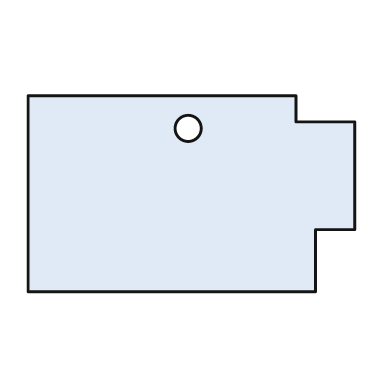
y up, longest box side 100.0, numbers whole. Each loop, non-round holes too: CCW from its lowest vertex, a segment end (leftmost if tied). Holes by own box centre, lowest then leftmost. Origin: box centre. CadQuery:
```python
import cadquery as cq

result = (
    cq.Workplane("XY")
    .moveTo(-50.0, -30.0)
    .lineTo(38.0, -30.0)
    .lineTo(38.0, -11.0)
    .lineTo(50.0, -11.0)
    .lineTo(50.0, 22.0)
    .lineTo(32.0, 22.0)
    .lineTo(32.0, 30.0)
    .lineTo(-50.0, 30.0)
    .close()
    .moveTo(-1.0, 20.0)
    .circle(4.0)
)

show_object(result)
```